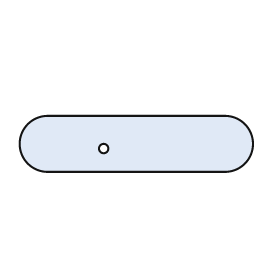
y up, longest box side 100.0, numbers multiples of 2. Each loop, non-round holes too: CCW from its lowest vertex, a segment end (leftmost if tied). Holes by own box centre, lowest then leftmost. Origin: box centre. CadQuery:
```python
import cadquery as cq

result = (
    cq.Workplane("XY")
    .moveTo(-38.0, -12.0)
    .lineTo(38.0, -12.0)
    .threePointArc((50.0, 0.0), (38.0, 12.0))
    .lineTo(-38.0, 12.0)
    .threePointArc((-50.0, 0.0), (-38.0, -12.0))
    .close()
    .moveTo(-14.0, -2.0)
    .circle(2.0)
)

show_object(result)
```